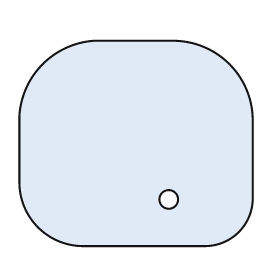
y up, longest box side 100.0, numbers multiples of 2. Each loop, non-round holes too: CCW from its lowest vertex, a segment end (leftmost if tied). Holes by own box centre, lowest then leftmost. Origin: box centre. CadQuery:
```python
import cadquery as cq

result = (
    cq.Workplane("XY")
    .moveTo(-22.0, -44.0)
    .lineTo(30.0, -44.0)
    .threePointArc((44.0, -38.0), (50.0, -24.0))
    .lineTo(50.0, 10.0)
    .threePointArc((40.0, 34.0), (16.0, 44.0))
    .lineTo(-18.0, 44.0)
    .threePointArc((-40.0, 34.0), (-50.0, 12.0))
    .lineTo(-50.0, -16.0)
    .threePointArc((-42.0, -36.0), (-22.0, -44.0))
    .close()
    .moveTo(14.0, -24.0)
    .circle(4.0)
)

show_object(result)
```